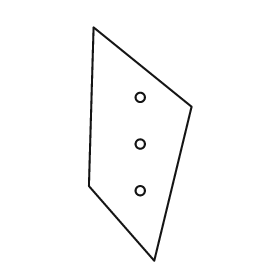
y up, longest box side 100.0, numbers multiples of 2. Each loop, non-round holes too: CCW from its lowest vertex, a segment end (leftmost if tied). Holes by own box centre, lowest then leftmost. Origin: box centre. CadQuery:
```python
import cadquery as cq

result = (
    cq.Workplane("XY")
    .moveTo(6.0, -50.0)
    .lineTo(22.0, 16.0)
    .lineTo(-20.0, 50.0)
    .lineTo(-22.0, -18.0)
    .close()
    .moveTo(0.0, -20.0)
    .circle(2.0)
    .moveTo(0.0, 0.0)
    .circle(2.0)
    .moveTo(0.0, 20.0)
    .circle(2.0)
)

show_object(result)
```